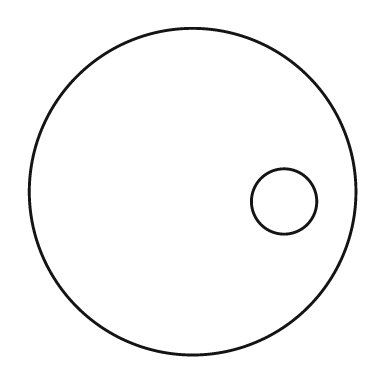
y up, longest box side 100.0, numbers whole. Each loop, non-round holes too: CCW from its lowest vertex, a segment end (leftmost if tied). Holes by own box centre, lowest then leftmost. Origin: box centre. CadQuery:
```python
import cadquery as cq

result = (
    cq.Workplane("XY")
    .moveTo(0.0, 0.0)
    .circle(50.0)
    .moveTo(28.0, -3.0)
    .circle(10.0)
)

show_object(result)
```